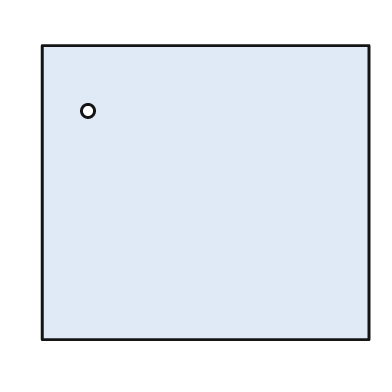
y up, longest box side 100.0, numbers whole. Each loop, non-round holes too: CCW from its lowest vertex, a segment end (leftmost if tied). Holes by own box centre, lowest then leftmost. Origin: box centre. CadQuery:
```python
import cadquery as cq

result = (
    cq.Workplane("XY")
    .moveTo(-50.0, -45.0)
    .lineTo(50.0, -45.0)
    .lineTo(50.0, 45.0)
    .lineTo(-50.0, 45.0)
    .close()
    .moveTo(-36.0, 25.0)
    .circle(2.0)
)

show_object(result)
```